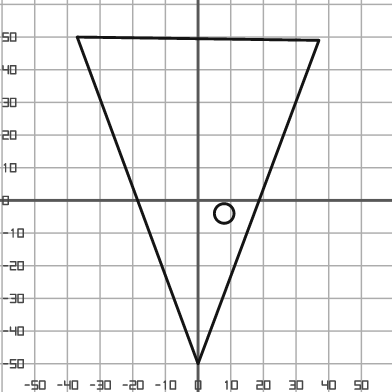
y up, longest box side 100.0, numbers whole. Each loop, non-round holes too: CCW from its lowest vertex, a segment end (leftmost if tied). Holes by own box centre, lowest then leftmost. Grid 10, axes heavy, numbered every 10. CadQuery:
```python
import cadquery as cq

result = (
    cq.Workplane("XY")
    .moveTo(0.0, -50.0)
    .lineTo(37.0, 49.0)
    .lineTo(-37.0, 50.0)
    .close()
    .moveTo(8.0, -4.0)
    .circle(3.0)
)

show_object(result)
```